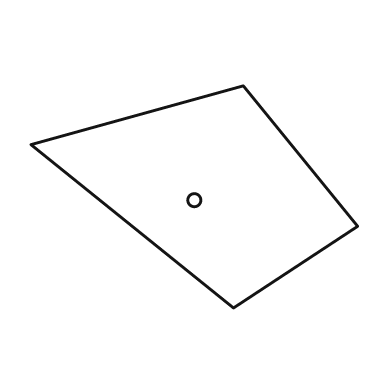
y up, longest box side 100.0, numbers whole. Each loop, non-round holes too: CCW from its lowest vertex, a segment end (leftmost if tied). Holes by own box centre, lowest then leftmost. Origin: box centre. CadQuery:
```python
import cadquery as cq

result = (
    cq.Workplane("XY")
    .moveTo(12.0, -34.0)
    .lineTo(50.0, -9.0)
    .lineTo(15.0, 34.0)
    .lineTo(-50.0, 16.0)
    .close()
    .moveTo(0.0, -1.0)
    .circle(2.0)
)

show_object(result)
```